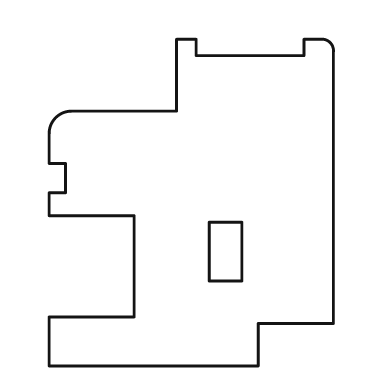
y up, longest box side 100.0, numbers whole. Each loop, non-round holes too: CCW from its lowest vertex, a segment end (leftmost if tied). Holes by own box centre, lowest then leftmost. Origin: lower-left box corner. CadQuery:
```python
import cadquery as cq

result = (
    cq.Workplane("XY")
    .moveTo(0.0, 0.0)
    .lineTo(64.0, 0.0)
    .lineTo(64.0, 13.0)
    .lineTo(87.0, 13.0)
    .lineTo(87.0, 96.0)
    .threePointArc((86.0, 99.0), (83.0, 100.0))
    .lineTo(78.0, 100.0)
    .lineTo(78.0, 95.0)
    .lineTo(45.0, 95.0)
    .lineTo(45.0, 100.0)
    .lineTo(39.0, 100.0)
    .lineTo(39.0, 78.0)
    .lineTo(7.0, 78.0)
    .threePointArc((2.0, 76.0), (0.0, 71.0))
    .lineTo(0.0, 62.0)
    .lineTo(5.0, 62.0)
    .lineTo(5.0, 53.0)
    .lineTo(0.0, 53.0)
    .lineTo(0.0, 46.0)
    .lineTo(26.0, 46.0)
    .lineTo(26.0, 15.0)
    .lineTo(0.0, 15.0)
    .close()
    .moveTo(49.0, 26.0)
    .lineTo(59.0, 26.0)
    .lineTo(59.0, 44.0)
    .lineTo(49.0, 44.0)
    .close()
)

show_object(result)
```